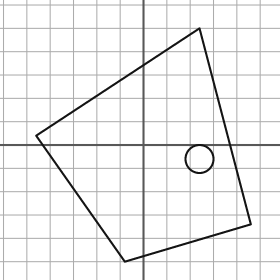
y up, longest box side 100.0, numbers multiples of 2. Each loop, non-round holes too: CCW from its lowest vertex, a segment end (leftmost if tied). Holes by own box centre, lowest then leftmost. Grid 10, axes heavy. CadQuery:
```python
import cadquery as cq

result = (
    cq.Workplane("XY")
    .moveTo(-8.0, -50.0)
    .lineTo(46.0, -34.0)
    .lineTo(24.0, 50.0)
    .lineTo(-46.0, 4.0)
    .close()
    .moveTo(24.0, -6.0)
    .circle(6.0)
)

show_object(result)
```